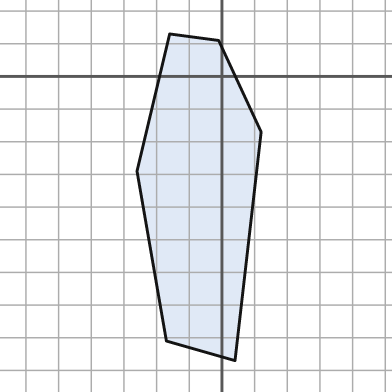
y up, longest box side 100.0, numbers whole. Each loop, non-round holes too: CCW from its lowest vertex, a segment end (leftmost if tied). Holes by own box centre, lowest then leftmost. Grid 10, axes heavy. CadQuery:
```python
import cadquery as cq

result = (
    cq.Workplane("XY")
    .moveTo(4.0, -87.0)
    .lineTo(12.0, -17.0)
    .lineTo(-1.0, 11.0)
    .lineTo(-16.0, 13.0)
    .lineTo(-26.0, -29.0)
    .lineTo(-17.0, -81.0)
    .close()
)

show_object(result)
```